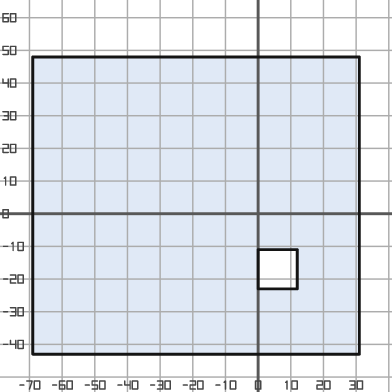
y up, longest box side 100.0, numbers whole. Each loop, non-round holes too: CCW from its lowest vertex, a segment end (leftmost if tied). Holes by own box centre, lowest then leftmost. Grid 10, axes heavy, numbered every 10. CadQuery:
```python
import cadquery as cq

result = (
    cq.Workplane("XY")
    .moveTo(-69.0, -43.0)
    .lineTo(31.0, -43.0)
    .lineTo(31.0, 48.0)
    .lineTo(-69.0, 48.0)
    .close()
    .moveTo(0.0, -23.0)
    .lineTo(12.0, -23.0)
    .lineTo(12.0, -11.0)
    .lineTo(0.0, -11.0)
    .close()
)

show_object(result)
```